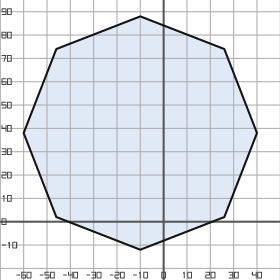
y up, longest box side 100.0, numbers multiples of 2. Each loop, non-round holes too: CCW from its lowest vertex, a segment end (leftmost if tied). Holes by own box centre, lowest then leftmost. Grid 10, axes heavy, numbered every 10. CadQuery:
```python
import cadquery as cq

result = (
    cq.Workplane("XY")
    .moveTo(-10.0, -12.0)
    .lineTo(26.0, 2.0)
    .lineTo(40.0, 38.0)
    .lineTo(26.0, 74.0)
    .lineTo(-10.0, 88.0)
    .lineTo(-46.0, 74.0)
    .lineTo(-60.0, 38.0)
    .lineTo(-46.0, 2.0)
    .close()
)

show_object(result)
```